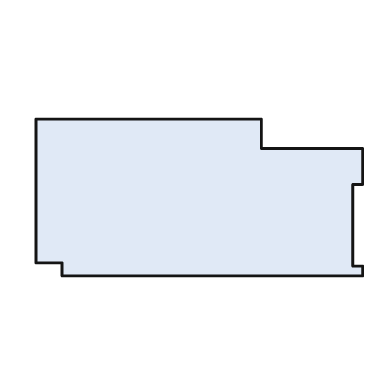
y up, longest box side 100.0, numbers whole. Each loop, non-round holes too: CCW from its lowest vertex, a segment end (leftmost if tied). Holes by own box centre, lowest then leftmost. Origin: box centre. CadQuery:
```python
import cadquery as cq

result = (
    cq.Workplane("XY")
    .moveTo(-42.0, -24.0)
    .lineTo(50.0, -24.0)
    .lineTo(50.0, -21.0)
    .lineTo(47.0, -21.0)
    .lineTo(47.0, 4.0)
    .lineTo(50.0, 4.0)
    .lineTo(50.0, 15.0)
    .lineTo(19.0, 15.0)
    .lineTo(19.0, 24.0)
    .lineTo(-50.0, 24.0)
    .lineTo(-50.0, -20.0)
    .lineTo(-42.0, -20.0)
    .close()
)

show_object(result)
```